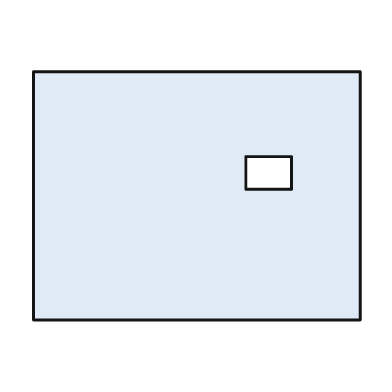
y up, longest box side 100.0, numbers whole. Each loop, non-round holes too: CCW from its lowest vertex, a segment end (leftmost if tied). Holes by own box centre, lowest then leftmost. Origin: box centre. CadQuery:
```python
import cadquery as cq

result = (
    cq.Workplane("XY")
    .moveTo(-50.0, -38.0)
    .lineTo(50.0, -38.0)
    .lineTo(50.0, 38.0)
    .lineTo(-50.0, 38.0)
    .close()
    .moveTo(15.0, 2.0)
    .lineTo(29.0, 2.0)
    .lineTo(29.0, 12.0)
    .lineTo(15.0, 12.0)
    .close()
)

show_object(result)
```